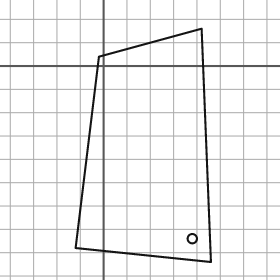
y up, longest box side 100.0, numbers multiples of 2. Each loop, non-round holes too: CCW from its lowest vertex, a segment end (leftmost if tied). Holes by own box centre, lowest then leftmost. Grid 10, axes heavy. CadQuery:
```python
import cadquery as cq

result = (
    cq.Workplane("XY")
    .moveTo(46.0, -84.0)
    .lineTo(42.0, 16.0)
    .lineTo(-2.0, 4.0)
    .lineTo(-12.0, -78.0)
    .close()
    .moveTo(38.0, -74.0)
    .circle(2.0)
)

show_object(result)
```